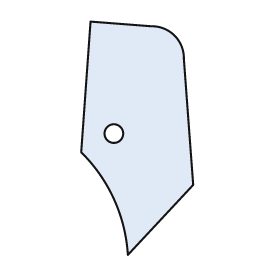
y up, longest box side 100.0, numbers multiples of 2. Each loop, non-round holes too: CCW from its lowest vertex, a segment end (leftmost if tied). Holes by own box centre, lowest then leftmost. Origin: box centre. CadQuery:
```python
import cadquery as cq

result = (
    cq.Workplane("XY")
    .moveTo(-4.0, -50.0)
    .lineTo(24.0, -20.0)
    .lineTo(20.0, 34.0)
    .threePointArc((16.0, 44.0), (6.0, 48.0))
    .lineTo(-20.0, 50.0)
    .lineTo(-24.0, -6.0)
    .threePointArc((-10.0, -26.0), (-4.0, -50.0))
    .close()
    .moveTo(-10.0, 2.0)
    .circle(4.0)
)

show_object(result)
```